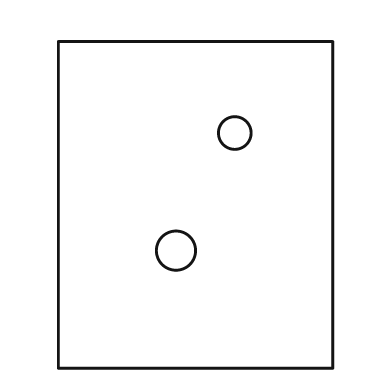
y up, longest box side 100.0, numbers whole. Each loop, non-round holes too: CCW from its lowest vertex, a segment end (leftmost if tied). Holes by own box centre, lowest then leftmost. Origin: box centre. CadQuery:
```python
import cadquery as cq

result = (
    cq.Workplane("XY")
    .moveTo(-42.0, -50.0)
    .lineTo(42.0, -50.0)
    .lineTo(42.0, 50.0)
    .lineTo(-42.0, 50.0)
    .close()
    .moveTo(-6.0, -14.0)
    .circle(6.0)
    .moveTo(12.0, 22.0)
    .circle(5.0)
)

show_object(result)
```